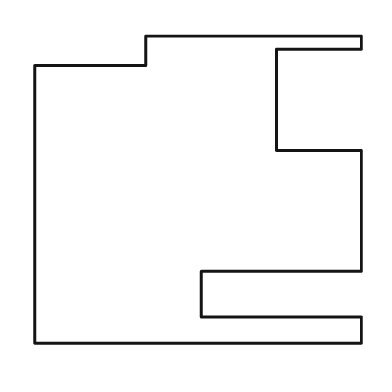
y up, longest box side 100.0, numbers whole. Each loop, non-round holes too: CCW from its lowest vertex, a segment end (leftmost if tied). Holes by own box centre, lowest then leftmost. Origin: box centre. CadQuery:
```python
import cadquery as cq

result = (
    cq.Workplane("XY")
    .moveTo(-50.0, -47.0)
    .lineTo(50.0, -47.0)
    .lineTo(50.0, -39.0)
    .lineTo(1.0, -39.0)
    .lineTo(1.0, -25.0)
    .lineTo(50.0, -25.0)
    .lineTo(50.0, 12.0)
    .lineTo(24.0, 12.0)
    .lineTo(24.0, 43.0)
    .lineTo(50.0, 43.0)
    .lineTo(50.0, 47.0)
    .lineTo(-16.0, 47.0)
    .lineTo(-16.0, 38.0)
    .lineTo(-50.0, 38.0)
    .close()
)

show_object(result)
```